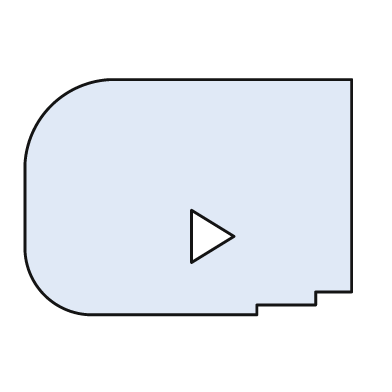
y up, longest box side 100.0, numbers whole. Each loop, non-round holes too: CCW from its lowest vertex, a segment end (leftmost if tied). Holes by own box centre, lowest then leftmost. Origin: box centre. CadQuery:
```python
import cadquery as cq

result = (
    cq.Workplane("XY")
    .moveTo(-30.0, -36.0)
    .lineTo(21.0, -36.0)
    .lineTo(21.0, -33.0)
    .lineTo(39.0, -33.0)
    .lineTo(39.0, -29.0)
    .lineTo(50.0, -29.0)
    .lineTo(50.0, 36.0)
    .lineTo(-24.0, 36.0)
    .threePointArc((-42.0, 28.0), (-50.0, 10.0))
    .lineTo(-50.0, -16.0)
    .threePointArc((-44.0, -30.0), (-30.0, -36.0))
    .close()
    .moveTo(1.0, -20.0)
    .lineTo(14.0, -12.0)
    .lineTo(1.0, -4.0)
    .close()
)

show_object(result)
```